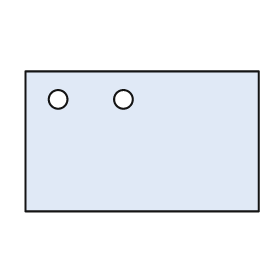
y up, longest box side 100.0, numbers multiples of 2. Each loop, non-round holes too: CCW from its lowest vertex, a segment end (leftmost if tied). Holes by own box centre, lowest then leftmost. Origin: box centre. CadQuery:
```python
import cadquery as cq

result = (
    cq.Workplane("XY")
    .moveTo(-50.0, -30.0)
    .lineTo(50.0, -30.0)
    .lineTo(50.0, 30.0)
    .lineTo(-50.0, 30.0)
    .close()
    .moveTo(-36.0, 18.0)
    .circle(4.0)
    .moveTo(-8.0, 18.0)
    .circle(4.0)
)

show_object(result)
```